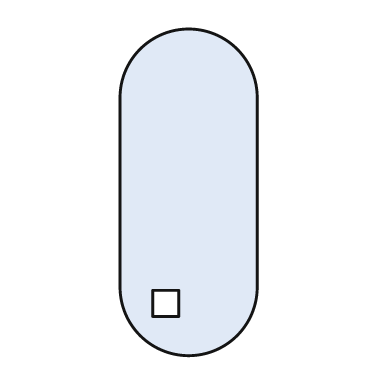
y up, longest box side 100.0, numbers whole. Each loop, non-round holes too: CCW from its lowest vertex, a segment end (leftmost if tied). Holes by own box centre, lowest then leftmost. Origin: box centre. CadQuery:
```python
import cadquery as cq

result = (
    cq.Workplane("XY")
    .moveTo(-21.0, -29.0)
    .threePointArc((0.0, -50.0), (21.0, -29.0))
    .lineTo(21.0, 29.0)
    .threePointArc((0.0, 50.0), (-21.0, 29.0))
    .close()
    .moveTo(-11.0, -38.0)
    .lineTo(-3.0, -38.0)
    .lineTo(-3.0, -30.0)
    .lineTo(-11.0, -30.0)
    .close()
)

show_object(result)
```